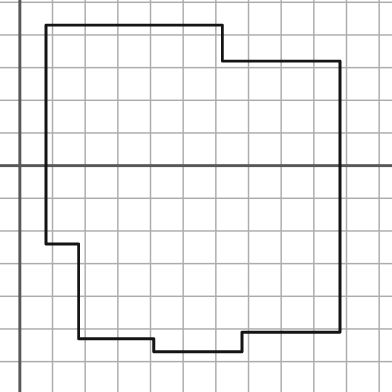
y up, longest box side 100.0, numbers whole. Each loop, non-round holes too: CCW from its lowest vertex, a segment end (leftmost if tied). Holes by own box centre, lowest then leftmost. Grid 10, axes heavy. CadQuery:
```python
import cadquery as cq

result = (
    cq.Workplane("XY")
    .moveTo(41.0, -57.0)
    .lineTo(68.0, -57.0)
    .lineTo(68.0, -51.0)
    .lineTo(98.0, -51.0)
    .lineTo(98.0, 32.0)
    .lineTo(62.0, 32.0)
    .lineTo(62.0, 43.0)
    .lineTo(8.0, 43.0)
    .lineTo(8.0, -24.0)
    .lineTo(18.0, -24.0)
    .lineTo(18.0, -53.0)
    .lineTo(41.0, -53.0)
    .close()
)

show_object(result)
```